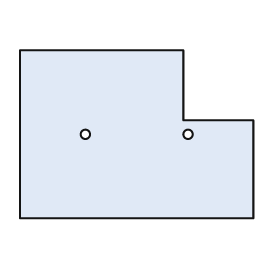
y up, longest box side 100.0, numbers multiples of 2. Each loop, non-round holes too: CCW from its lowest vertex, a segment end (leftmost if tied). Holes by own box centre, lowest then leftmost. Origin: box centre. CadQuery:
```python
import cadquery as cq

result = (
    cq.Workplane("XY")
    .moveTo(-50.0, -36.0)
    .lineTo(50.0, -36.0)
    .lineTo(50.0, 6.0)
    .lineTo(20.0, 6.0)
    .lineTo(20.0, 36.0)
    .lineTo(-50.0, 36.0)
    .close()
    .moveTo(-22.0, 0.0)
    .circle(2.0)
    .moveTo(22.0, 0.0)
    .circle(2.0)
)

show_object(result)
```